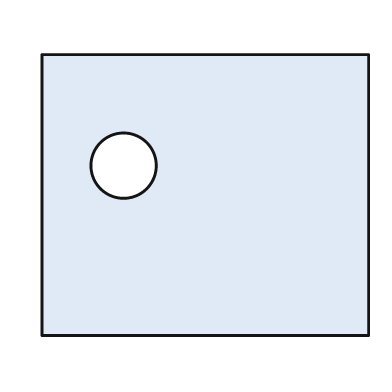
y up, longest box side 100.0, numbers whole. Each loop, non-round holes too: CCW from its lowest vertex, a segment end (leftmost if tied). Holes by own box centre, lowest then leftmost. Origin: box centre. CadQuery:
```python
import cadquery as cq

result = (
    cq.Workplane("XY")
    .moveTo(-50.0, -43.0)
    .lineTo(50.0, -43.0)
    .lineTo(50.0, 43.0)
    .lineTo(-50.0, 43.0)
    .close()
    .moveTo(-25.0, 9.0)
    .circle(10.0)
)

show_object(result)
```